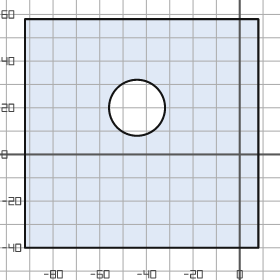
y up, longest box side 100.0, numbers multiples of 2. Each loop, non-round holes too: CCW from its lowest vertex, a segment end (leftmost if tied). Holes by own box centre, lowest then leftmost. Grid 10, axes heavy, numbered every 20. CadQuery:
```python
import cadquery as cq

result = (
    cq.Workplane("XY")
    .moveTo(-92.0, -40.0)
    .lineTo(8.0, -40.0)
    .lineTo(8.0, 58.0)
    .lineTo(-92.0, 58.0)
    .close()
    .moveTo(-44.0, 20.0)
    .circle(12.0)
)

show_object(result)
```